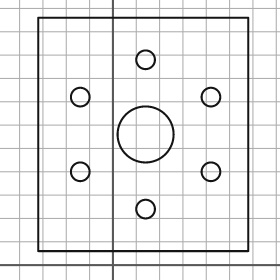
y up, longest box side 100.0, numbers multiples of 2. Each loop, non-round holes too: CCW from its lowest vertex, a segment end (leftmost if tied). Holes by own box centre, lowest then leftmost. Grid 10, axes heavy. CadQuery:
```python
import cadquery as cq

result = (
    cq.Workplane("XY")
    .moveTo(-32.0, 6.0)
    .lineTo(58.0, 6.0)
    .lineTo(58.0, 106.0)
    .lineTo(-32.0, 106.0)
    .close()
    .moveTo(14.0, 24.0)
    .circle(4.0)
    .moveTo(-14.0, 40.0)
    .circle(4.0)
    .moveTo(42.0, 40.0)
    .circle(4.0)
    .moveTo(14.0, 56.0)
    .circle(12.0)
    .moveTo(-14.0, 72.0)
    .circle(4.0)
    .moveTo(42.0, 72.0)
    .circle(4.0)
    .moveTo(14.0, 88.0)
    .circle(4.0)
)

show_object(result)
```